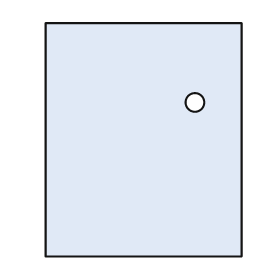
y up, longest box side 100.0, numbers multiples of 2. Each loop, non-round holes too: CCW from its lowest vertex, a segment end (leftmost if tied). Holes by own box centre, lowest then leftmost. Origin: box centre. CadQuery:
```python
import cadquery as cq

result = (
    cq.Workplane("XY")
    .moveTo(-42.0, -50.0)
    .lineTo(42.0, -50.0)
    .lineTo(42.0, 50.0)
    .lineTo(-42.0, 50.0)
    .close()
    .moveTo(22.0, 16.0)
    .circle(4.0)
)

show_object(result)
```